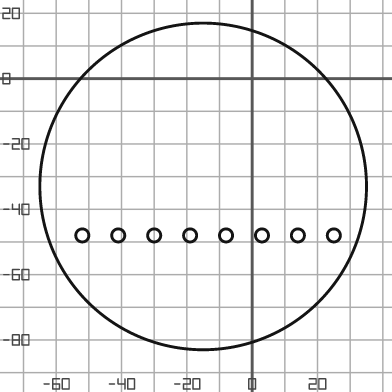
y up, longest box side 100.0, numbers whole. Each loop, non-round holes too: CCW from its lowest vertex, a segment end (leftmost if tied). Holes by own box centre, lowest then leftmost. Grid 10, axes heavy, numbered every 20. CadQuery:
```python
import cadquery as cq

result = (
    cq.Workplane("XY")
    .moveTo(-15.0, -33.0)
    .circle(50.0)
    .moveTo(-52.0, -48.0)
    .circle(2.0)
    .moveTo(-41.0, -48.0)
    .circle(2.0)
    .moveTo(-30.0, -48.0)
    .circle(2.0)
    .moveTo(-19.0, -48.0)
    .circle(2.0)
    .moveTo(-8.0, -48.0)
    .circle(2.0)
    .moveTo(3.0, -48.0)
    .circle(2.0)
    .moveTo(14.0, -48.0)
    .circle(2.0)
    .moveTo(25.0, -48.0)
    .circle(2.0)
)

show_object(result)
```